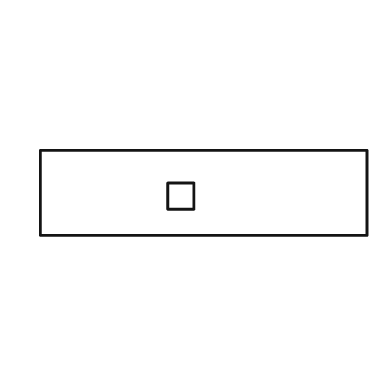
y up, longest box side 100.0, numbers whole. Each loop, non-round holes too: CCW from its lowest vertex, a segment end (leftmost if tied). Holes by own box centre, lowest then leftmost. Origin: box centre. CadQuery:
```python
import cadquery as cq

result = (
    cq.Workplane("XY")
    .moveTo(-50.0, -13.0)
    .lineTo(50.0, -13.0)
    .lineTo(50.0, 13.0)
    .lineTo(-50.0, 13.0)
    .close()
    .moveTo(-11.0, -5.0)
    .lineTo(-3.0, -5.0)
    .lineTo(-3.0, 3.0)
    .lineTo(-11.0, 3.0)
    .close()
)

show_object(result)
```